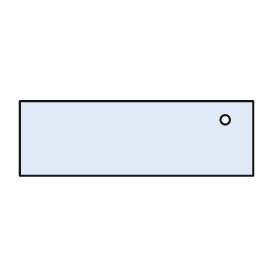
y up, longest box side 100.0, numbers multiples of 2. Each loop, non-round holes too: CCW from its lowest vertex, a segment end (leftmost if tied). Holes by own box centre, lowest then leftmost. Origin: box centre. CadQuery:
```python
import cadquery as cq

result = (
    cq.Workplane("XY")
    .moveTo(-50.0, -16.0)
    .lineTo(50.0, -16.0)
    .lineTo(50.0, 16.0)
    .lineTo(-50.0, 16.0)
    .close()
    .moveTo(38.0, 8.0)
    .circle(2.0)
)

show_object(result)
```